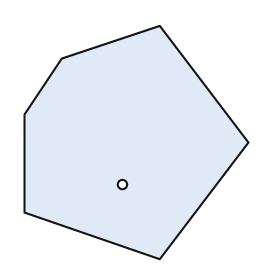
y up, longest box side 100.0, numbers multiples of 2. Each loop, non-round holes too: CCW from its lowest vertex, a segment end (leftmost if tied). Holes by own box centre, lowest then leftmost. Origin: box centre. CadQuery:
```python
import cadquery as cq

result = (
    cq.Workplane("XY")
    .moveTo(10.0, -50.0)
    .lineTo(48.0, 0.0)
    .lineTo(10.0, 50.0)
    .lineTo(-32.0, 36.0)
    .lineTo(-48.0, 12.0)
    .lineTo(-48.0, -30.0)
    .close()
    .moveTo(-6.0, -18.0)
    .circle(2.0)
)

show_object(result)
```